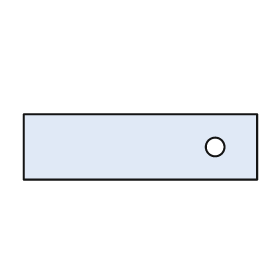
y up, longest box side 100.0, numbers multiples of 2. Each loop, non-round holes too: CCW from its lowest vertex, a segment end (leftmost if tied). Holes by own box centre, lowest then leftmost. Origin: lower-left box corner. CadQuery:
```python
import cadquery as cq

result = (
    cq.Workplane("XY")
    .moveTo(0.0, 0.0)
    .lineTo(100.0, 0.0)
    .lineTo(100.0, 28.0)
    .lineTo(0.0, 28.0)
    .close()
    .moveTo(82.0, 14.0)
    .circle(4.0)
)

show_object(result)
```